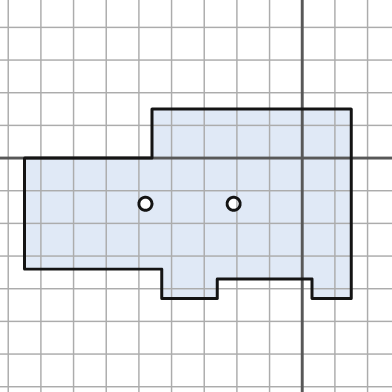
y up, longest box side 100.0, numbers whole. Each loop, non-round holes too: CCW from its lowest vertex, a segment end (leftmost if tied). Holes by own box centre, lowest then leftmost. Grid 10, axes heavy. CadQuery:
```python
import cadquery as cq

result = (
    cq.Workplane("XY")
    .moveTo(-43.0, -43.0)
    .lineTo(-26.0, -43.0)
    .lineTo(-26.0, -37.0)
    .lineTo(3.0, -37.0)
    .lineTo(3.0, -43.0)
    .lineTo(15.0, -43.0)
    .lineTo(15.0, 15.0)
    .lineTo(-46.0, 15.0)
    .lineTo(-46.0, 0.0)
    .lineTo(-85.0, 0.0)
    .lineTo(-85.0, -34.0)
    .lineTo(-43.0, -34.0)
    .close()
    .moveTo(-48.0, -14.0)
    .circle(2.0)
    .moveTo(-21.0, -14.0)
    .circle(2.0)
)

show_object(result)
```